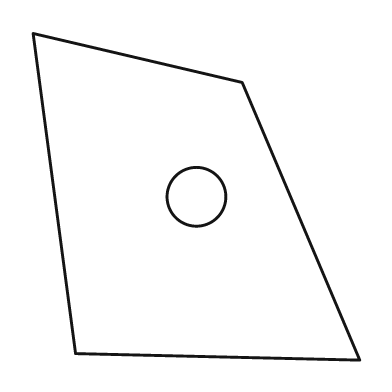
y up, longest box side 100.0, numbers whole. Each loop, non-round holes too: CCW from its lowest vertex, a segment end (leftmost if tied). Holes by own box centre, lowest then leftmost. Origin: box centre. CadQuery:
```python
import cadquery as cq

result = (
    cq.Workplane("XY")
    .moveTo(50.0, -50.0)
    .lineTo(14.0, 35.0)
    .lineTo(-50.0, 50.0)
    .lineTo(-37.0, -48.0)
    .close()
    .moveTo(0.0, 0.0)
    .circle(9.0)
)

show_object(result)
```